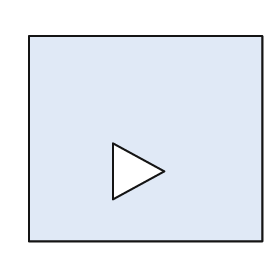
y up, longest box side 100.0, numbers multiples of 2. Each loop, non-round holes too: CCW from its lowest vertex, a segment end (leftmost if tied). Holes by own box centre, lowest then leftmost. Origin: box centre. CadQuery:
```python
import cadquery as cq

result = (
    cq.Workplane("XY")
    .moveTo(-50.0, -44.0)
    .lineTo(50.0, -44.0)
    .lineTo(50.0, 44.0)
    .lineTo(-50.0, 44.0)
    .close()
    .moveTo(-14.0, -26.0)
    .lineTo(8.0, -14.0)
    .lineTo(-14.0, -2.0)
    .close()
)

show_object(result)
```